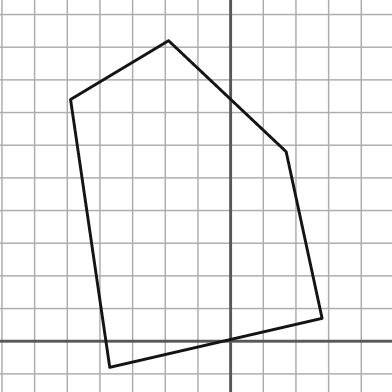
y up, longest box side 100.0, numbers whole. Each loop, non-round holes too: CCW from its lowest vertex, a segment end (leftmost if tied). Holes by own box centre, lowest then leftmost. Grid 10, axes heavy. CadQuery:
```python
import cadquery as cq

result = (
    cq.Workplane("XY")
    .moveTo(-37.0, -8.0)
    .lineTo(28.0, 7.0)
    .lineTo(17.0, 58.0)
    .lineTo(-19.0, 92.0)
    .lineTo(-49.0, 74.0)
    .close()
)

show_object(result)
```